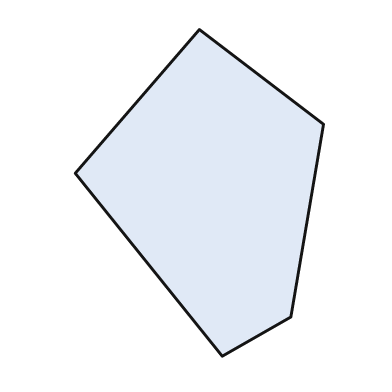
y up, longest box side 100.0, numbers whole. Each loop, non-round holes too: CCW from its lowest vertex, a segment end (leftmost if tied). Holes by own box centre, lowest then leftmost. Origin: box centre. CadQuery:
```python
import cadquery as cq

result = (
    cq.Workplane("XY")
    .moveTo(7.0, -50.0)
    .lineTo(28.0, -38.0)
    .lineTo(38.0, 21.0)
    .lineTo(0.0, 50.0)
    .lineTo(-38.0, 6.0)
    .close()
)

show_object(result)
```